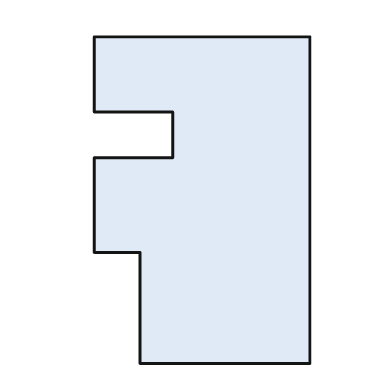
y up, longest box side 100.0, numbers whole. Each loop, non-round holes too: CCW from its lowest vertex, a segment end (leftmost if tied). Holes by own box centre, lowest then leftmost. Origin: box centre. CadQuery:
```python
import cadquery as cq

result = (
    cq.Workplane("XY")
    .moveTo(-19.0, -50.0)
    .lineTo(33.0, -50.0)
    .lineTo(33.0, 50.0)
    .lineTo(-33.0, 50.0)
    .lineTo(-33.0, 27.0)
    .lineTo(-9.0, 27.0)
    .lineTo(-9.0, 13.0)
    .lineTo(-33.0, 13.0)
    .lineTo(-33.0, -16.0)
    .lineTo(-19.0, -16.0)
    .close()
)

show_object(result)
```